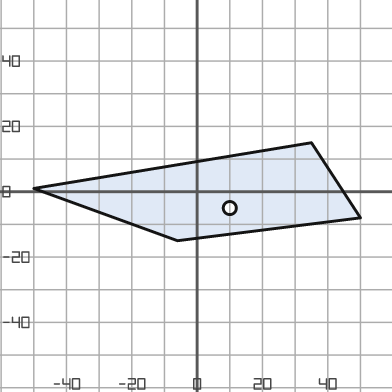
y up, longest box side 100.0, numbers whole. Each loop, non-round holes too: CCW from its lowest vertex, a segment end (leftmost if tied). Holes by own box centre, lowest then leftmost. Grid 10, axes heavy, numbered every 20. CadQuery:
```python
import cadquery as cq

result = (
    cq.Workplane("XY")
    .moveTo(-6.0, -15.0)
    .lineTo(50.0, -8.0)
    .lineTo(35.0, 15.0)
    .lineTo(-50.0, 1.0)
    .close()
    .moveTo(10.0, -5.0)
    .circle(2.0)
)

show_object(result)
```